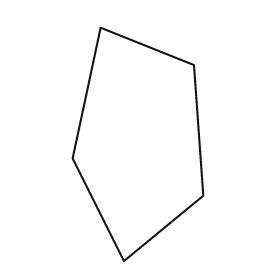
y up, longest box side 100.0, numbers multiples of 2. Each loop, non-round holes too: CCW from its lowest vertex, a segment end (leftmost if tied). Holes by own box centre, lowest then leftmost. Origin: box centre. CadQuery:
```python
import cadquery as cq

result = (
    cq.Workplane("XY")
    .moveTo(-6.0, -50.0)
    .lineTo(28.0, -22.0)
    .lineTo(24.0, 34.0)
    .lineTo(-16.0, 50.0)
    .lineTo(-28.0, -6.0)
    .close()
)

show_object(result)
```